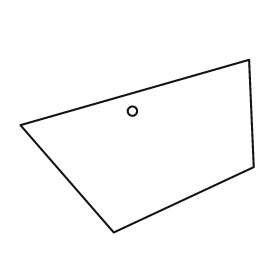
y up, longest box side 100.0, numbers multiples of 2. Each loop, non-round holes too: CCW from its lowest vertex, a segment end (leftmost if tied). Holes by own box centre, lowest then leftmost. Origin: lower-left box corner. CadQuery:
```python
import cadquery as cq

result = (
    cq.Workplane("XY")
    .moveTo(40.0, 0.0)
    .lineTo(100.0, 28.0)
    .lineTo(98.0, 74.0)
    .lineTo(0.0, 46.0)
    .close()
    .moveTo(48.0, 52.0)
    .circle(2.0)
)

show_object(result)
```